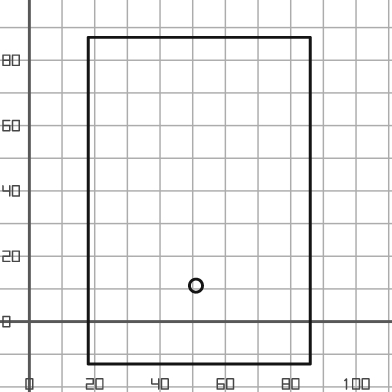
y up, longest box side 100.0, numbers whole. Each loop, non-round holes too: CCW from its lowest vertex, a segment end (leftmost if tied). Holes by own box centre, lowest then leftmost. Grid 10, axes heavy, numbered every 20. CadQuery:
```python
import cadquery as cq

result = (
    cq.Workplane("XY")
    .moveTo(18.0, -13.0)
    .lineTo(86.0, -13.0)
    .lineTo(86.0, 87.0)
    .lineTo(18.0, 87.0)
    .close()
    .moveTo(51.0, 11.0)
    .circle(2.0)
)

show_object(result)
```